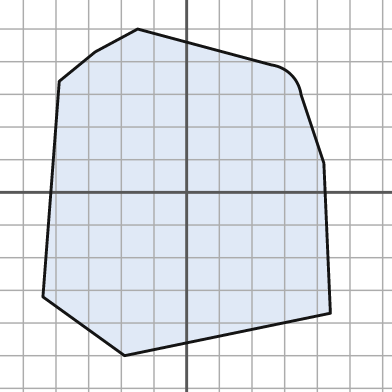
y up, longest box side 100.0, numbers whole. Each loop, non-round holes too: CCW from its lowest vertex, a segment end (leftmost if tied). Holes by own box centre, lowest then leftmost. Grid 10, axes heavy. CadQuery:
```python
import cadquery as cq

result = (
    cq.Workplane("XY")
    .moveTo(-19.0, -50.0)
    .lineTo(44.0, -37.0)
    .lineTo(42.0, 9.0)
    .lineTo(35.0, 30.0)
    .threePointArc((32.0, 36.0), (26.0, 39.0))
    .lineTo(-15.0, 50.0)
    .lineTo(-28.0, 43.0)
    .lineTo(-39.0, 34.0)
    .lineTo(-44.0, -32.0)
    .close()
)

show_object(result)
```